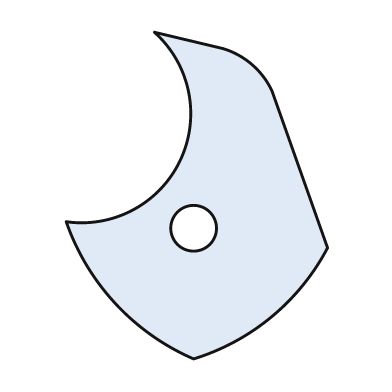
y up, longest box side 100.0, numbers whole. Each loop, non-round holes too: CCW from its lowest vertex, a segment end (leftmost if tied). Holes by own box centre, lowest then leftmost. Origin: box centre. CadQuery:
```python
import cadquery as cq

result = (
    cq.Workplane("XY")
    .moveTo(-1.0, -50.0)
    .threePointArc((23.0, -37.0), (40.0, -16.0))
    .lineTo(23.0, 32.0)
    .threePointArc((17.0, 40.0), (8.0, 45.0))
    .lineTo(-13.0, 50.0)
    .threePointArc((-5.0, 11.0), (-40.0, -8.0))
    .threePointArc((-25.0, -33.0), (-1.0, -50.0))
    .close()
    .moveTo(-1.0, -10.0)
    .circle(7.0)
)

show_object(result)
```